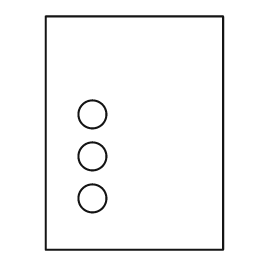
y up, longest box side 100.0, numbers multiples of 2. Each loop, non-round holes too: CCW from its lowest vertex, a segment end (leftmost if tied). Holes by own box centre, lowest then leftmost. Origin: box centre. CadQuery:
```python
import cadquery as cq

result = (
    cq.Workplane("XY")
    .moveTo(-38.0, -50.0)
    .lineTo(38.0, -50.0)
    .lineTo(38.0, 50.0)
    .lineTo(-38.0, 50.0)
    .close()
    .moveTo(-18.0, -28.0)
    .circle(6.0)
    .moveTo(-18.0, -10.0)
    .circle(6.0)
    .moveTo(-18.0, 8.0)
    .circle(6.0)
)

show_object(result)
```